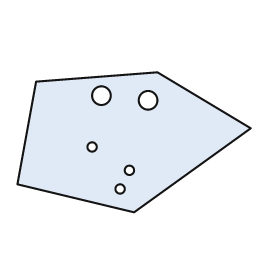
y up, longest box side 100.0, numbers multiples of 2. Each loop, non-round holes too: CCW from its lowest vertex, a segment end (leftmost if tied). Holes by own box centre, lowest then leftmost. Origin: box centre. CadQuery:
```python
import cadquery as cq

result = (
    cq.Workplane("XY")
    .moveTo(0.0, -30.0)
    .lineTo(50.0, 6.0)
    .lineTo(10.0, 30.0)
    .lineTo(-42.0, 26.0)
    .lineTo(-50.0, -18.0)
    .close()
    .moveTo(-6.0, -20.0)
    .circle(2.0)
    .moveTo(-2.0, -12.0)
    .circle(2.0)
    .moveTo(-18.0, -2.0)
    .circle(2.0)
    .moveTo(6.0, 18.0)
    .circle(4.0)
    .moveTo(-14.0, 20.0)
    .circle(4.0)
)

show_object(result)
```